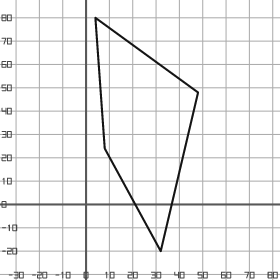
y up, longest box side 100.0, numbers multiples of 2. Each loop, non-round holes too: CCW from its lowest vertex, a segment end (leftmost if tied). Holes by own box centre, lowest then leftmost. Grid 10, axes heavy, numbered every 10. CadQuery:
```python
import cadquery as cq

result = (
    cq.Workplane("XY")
    .moveTo(32.0, -20.0)
    .lineTo(48.0, 48.0)
    .lineTo(4.0, 80.0)
    .lineTo(8.0, 24.0)
    .close()
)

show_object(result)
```